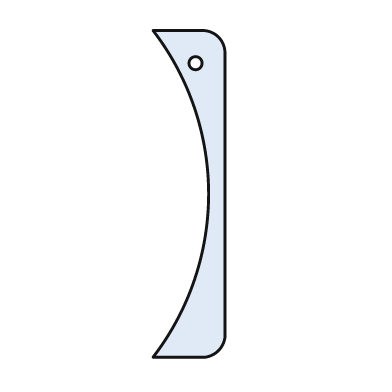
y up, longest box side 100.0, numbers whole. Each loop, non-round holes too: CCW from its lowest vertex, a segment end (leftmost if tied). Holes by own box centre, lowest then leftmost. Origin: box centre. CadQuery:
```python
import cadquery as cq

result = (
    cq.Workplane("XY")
    .moveTo(-11.0, -50.0)
    .lineTo(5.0, -50.0)
    .threePointArc((9.0, -48.0), (11.0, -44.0))
    .lineTo(11.0, 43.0)
    .threePointArc((9.0, 48.0), (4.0, 50.0))
    .lineTo(-11.0, 50.0)
    .threePointArc((6.0, 0.0), (-11.0, -50.0))
    .close()
    .moveTo(2.0, 40.0)
    .circle(2.0)
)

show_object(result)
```